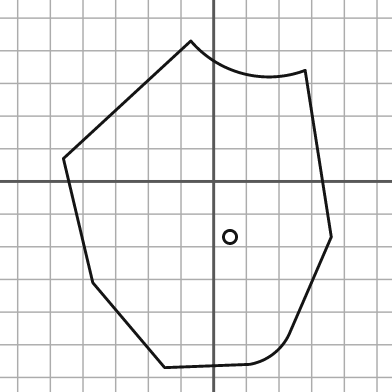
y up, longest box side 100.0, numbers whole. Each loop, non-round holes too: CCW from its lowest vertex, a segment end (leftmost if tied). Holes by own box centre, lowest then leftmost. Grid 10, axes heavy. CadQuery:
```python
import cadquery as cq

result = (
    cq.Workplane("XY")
    .moveTo(-15.0, -57.0)
    .lineTo(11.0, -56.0)
    .threePointArc((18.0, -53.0), (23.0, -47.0))
    .lineTo(36.0, -17.0)
    .lineTo(28.0, 34.0)
    .threePointArc((9.0, 33.0), (-7.0, 43.0))
    .lineTo(-46.0, 7.0)
    .lineTo(-37.0, -31.0)
    .close()
    .moveTo(5.0, -17.0)
    .circle(2.0)
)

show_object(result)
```